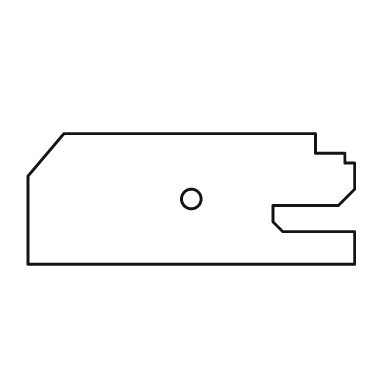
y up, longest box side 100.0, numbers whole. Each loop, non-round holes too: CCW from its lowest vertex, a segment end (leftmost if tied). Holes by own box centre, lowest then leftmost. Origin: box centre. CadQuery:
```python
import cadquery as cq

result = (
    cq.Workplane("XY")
    .moveTo(-50.0, -20.0)
    .lineTo(50.0, -20.0)
    .lineTo(50.0, -10.0)
    .lineTo(28.0, -10.0)
    .lineTo(25.0, -7.0)
    .lineTo(25.0, -2.0)
    .lineTo(45.0, -2.0)
    .lineTo(50.0, 3.0)
    .lineTo(50.0, 11.0)
    .lineTo(47.0, 11.0)
    .lineTo(47.0, 14.0)
    .lineTo(38.0, 14.0)
    .lineTo(38.0, 20.0)
    .lineTo(-39.0, 20.0)
    .lineTo(-50.0, 7.0)
    .close()
    .moveTo(0.0, 0.0)
    .circle(3.0)
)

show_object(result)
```